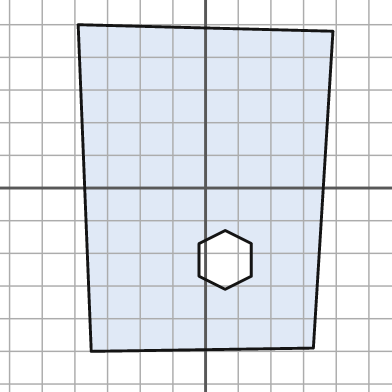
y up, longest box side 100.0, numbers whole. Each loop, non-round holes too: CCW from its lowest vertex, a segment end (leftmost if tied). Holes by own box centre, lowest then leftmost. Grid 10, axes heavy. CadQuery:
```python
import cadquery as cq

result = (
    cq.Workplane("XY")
    .moveTo(-35.0, -50.0)
    .lineTo(33.0, -49.0)
    .lineTo(39.0, 48.0)
    .lineTo(-39.0, 50.0)
    .close()
    .moveTo(6.0, -31.0)
    .lineTo(14.0, -27.0)
    .lineTo(14.0, -17.0)
    .lineTo(6.0, -13.0)
    .lineTo(-2.0, -17.0)
    .lineTo(-2.0, -27.0)
    .close()
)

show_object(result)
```